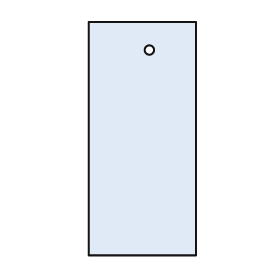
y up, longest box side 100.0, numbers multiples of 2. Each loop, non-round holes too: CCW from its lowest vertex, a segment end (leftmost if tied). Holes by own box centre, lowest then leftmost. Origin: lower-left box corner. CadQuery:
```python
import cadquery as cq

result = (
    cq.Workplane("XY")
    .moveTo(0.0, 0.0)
    .lineTo(46.0, 0.0)
    .lineTo(46.0, 100.0)
    .lineTo(0.0, 100.0)
    .close()
    .moveTo(26.0, 88.0)
    .circle(2.0)
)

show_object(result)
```